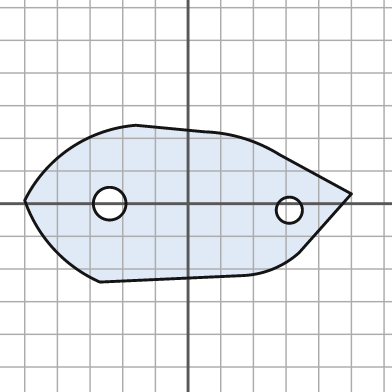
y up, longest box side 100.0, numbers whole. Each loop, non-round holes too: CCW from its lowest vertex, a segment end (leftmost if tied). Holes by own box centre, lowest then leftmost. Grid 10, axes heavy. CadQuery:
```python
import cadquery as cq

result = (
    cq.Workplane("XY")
    .moveTo(-27.0, -24.0)
    .lineTo(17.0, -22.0)
    .threePointArc((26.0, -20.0), (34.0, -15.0))
    .lineTo(50.0, 3.0)
    .lineTo(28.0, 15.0)
    .threePointArc((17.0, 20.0), (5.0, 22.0))
    .lineTo(-16.0, 24.0)
    .threePointArc((-36.0, 17.0), (-50.0, 1.0))
    .threePointArc((-41.0, -14.0), (-27.0, -24.0))
    .close()
    .moveTo(31.0, -2.0)
    .circle(4.0)
    .moveTo(-24.0, 0.0)
    .circle(5.0)
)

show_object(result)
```